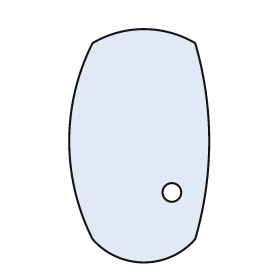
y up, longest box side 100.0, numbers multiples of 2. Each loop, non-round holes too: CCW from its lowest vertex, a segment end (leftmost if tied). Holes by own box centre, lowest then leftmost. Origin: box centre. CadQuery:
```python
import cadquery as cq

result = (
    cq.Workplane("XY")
    .moveTo(-20.0, -40.0)
    .threePointArc((2.0, -50.0), (24.0, -40.0))
    .threePointArc((30.0, 2.0), (24.0, 44.0))
    .threePointArc((2.0, 50.0), (-20.0, 44.0))
    .threePointArc((-30.0, 2.0), (-20.0, -40.0))
    .close()
    .moveTo(14.0, -20.0)
    .circle(4.0)
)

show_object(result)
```